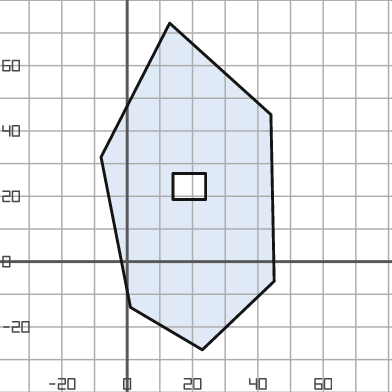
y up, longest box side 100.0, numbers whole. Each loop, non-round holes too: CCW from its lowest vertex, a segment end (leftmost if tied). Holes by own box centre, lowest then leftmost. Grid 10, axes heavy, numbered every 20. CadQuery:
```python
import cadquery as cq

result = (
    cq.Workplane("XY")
    .moveTo(23.0, -27.0)
    .lineTo(45.0, -6.0)
    .lineTo(44.0, 45.0)
    .lineTo(13.0, 73.0)
    .lineTo(-8.0, 32.0)
    .lineTo(1.0, -14.0)
    .close()
    .moveTo(14.0, 19.0)
    .lineTo(24.0, 19.0)
    .lineTo(24.0, 27.0)
    .lineTo(14.0, 27.0)
    .close()
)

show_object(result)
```